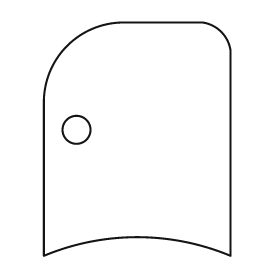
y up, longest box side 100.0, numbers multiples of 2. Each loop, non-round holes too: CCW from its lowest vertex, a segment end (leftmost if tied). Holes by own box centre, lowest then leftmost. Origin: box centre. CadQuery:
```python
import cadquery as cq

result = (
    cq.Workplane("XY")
    .moveTo(-40.0, -50.0)
    .threePointArc((0.0, -42.0), (40.0, -50.0))
    .lineTo(40.0, 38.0)
    .threePointArc((36.0, 46.0), (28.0, 50.0))
    .lineTo(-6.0, 50.0)
    .threePointArc((-30.0, 40.0), (-40.0, 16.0))
    .close()
    .moveTo(-26.0, 4.0)
    .circle(6.0)
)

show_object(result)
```